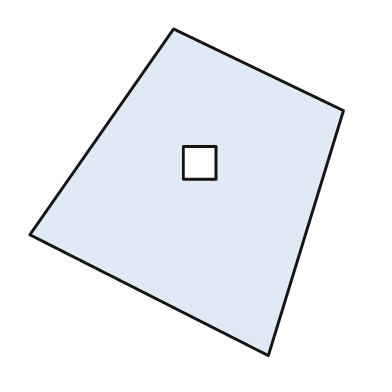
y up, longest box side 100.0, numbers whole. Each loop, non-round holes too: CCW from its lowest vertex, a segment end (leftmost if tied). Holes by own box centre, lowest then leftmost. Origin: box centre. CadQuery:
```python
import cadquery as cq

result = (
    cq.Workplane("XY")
    .moveTo(25.0, -50.0)
    .lineTo(48.0, 25.0)
    .lineTo(-4.0, 50.0)
    .lineTo(-48.0, -13.0)
    .close()
    .moveTo(-1.0, 4.0)
    .lineTo(9.0, 4.0)
    .lineTo(9.0, 14.0)
    .lineTo(-1.0, 14.0)
    .close()
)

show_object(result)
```